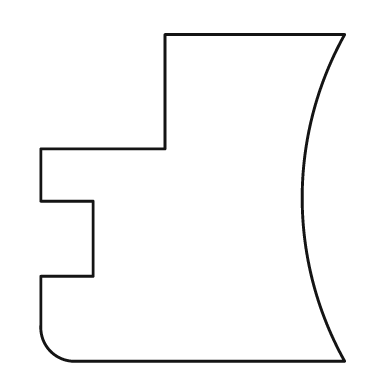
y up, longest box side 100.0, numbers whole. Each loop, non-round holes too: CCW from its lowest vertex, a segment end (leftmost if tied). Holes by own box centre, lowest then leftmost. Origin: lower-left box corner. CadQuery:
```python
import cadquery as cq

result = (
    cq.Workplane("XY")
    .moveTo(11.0, 0.0)
    .lineTo(93.0, 0.0)
    .threePointArc((80.0, 50.0), (93.0, 100.0))
    .lineTo(38.0, 100.0)
    .lineTo(38.0, 65.0)
    .lineTo(0.0, 65.0)
    .lineTo(0.0, 49.0)
    .lineTo(16.0, 49.0)
    .lineTo(16.0, 26.0)
    .lineTo(0.0, 26.0)
    .lineTo(0.0, 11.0)
    .threePointArc((3.0, 3.0), (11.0, 0.0))
    .close()
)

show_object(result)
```